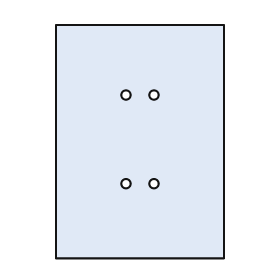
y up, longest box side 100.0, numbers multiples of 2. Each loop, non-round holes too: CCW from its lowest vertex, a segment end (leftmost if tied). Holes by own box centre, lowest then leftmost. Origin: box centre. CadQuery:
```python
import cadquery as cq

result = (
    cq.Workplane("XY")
    .moveTo(-36.0, -50.0)
    .lineTo(36.0, -50.0)
    .lineTo(36.0, 50.0)
    .lineTo(-36.0, 50.0)
    .close()
    .moveTo(-6.0, -18.0)
    .circle(2.0)
    .moveTo(6.0, -18.0)
    .circle(2.0)
    .moveTo(-6.0, 20.0)
    .circle(2.0)
    .moveTo(6.0, 20.0)
    .circle(2.0)
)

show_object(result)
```